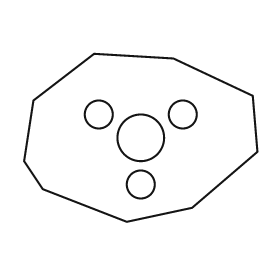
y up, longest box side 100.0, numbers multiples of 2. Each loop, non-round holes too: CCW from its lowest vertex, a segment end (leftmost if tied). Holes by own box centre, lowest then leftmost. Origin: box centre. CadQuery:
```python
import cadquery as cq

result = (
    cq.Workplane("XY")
    .moveTo(-6.0, -36.0)
    .lineTo(22.0, -30.0)
    .lineTo(50.0, -6.0)
    .lineTo(48.0, 18.0)
    .lineTo(14.0, 34.0)
    .lineTo(-20.0, 36.0)
    .lineTo(-46.0, 16.0)
    .lineTo(-50.0, -10.0)
    .lineTo(-42.0, -22.0)
    .close()
    .moveTo(0.0, -20.0)
    .circle(6.0)
    .moveTo(0.0, 0.0)
    .circle(10.0)
    .moveTo(-18.0, 10.0)
    .circle(6.0)
    .moveTo(18.0, 10.0)
    .circle(6.0)
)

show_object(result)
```